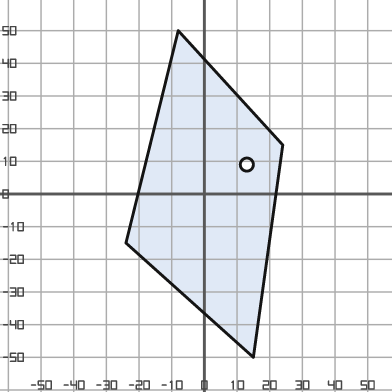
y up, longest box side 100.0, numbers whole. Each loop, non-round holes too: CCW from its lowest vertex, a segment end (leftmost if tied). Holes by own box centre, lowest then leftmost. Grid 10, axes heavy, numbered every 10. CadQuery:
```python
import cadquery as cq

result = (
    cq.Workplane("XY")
    .moveTo(15.0, -50.0)
    .lineTo(24.0, 15.0)
    .lineTo(-8.0, 50.0)
    .lineTo(-24.0, -15.0)
    .close()
    .moveTo(13.0, 9.0)
    .circle(2.0)
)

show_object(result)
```